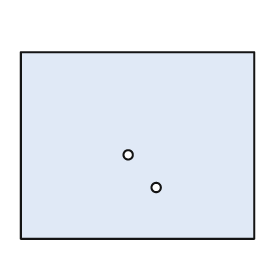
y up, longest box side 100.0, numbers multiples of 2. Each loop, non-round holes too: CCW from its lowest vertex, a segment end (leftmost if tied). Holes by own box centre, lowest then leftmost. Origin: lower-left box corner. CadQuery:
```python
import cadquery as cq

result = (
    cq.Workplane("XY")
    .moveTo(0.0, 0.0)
    .lineTo(100.0, 0.0)
    .lineTo(100.0, 80.0)
    .lineTo(0.0, 80.0)
    .close()
    .moveTo(58.0, 22.0)
    .circle(2.0)
    .moveTo(46.0, 36.0)
    .circle(2.0)
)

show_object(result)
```